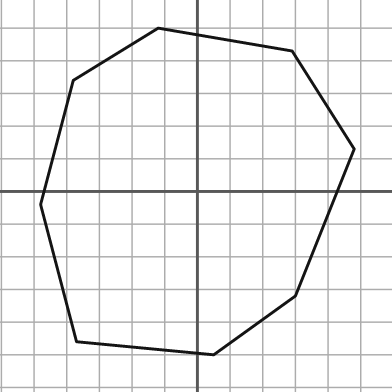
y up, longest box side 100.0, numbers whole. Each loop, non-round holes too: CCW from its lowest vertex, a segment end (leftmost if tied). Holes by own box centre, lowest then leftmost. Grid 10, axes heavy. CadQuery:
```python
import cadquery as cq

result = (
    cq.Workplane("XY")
    .moveTo(5.0, -50.0)
    .lineTo(30.0, -32.0)
    .lineTo(48.0, 13.0)
    .lineTo(29.0, 43.0)
    .lineTo(-12.0, 50.0)
    .lineTo(-38.0, 34.0)
    .lineTo(-48.0, -4.0)
    .lineTo(-37.0, -46.0)
    .close()
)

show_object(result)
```